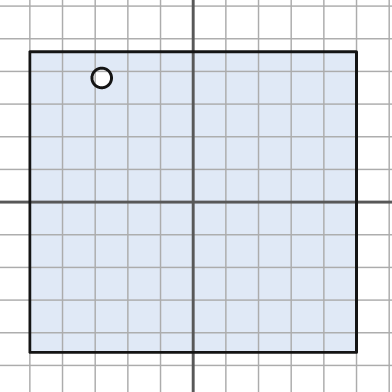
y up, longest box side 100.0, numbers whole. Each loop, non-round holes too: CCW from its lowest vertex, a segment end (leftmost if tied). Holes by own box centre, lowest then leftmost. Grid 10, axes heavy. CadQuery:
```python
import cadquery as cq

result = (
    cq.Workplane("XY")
    .moveTo(-50.0, -46.0)
    .lineTo(50.0, -46.0)
    .lineTo(50.0, 46.0)
    .lineTo(-50.0, 46.0)
    .close()
    .moveTo(-28.0, 38.0)
    .circle(3.0)
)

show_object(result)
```